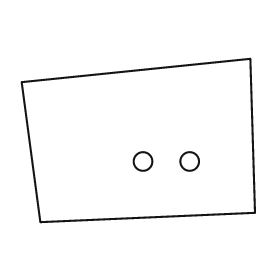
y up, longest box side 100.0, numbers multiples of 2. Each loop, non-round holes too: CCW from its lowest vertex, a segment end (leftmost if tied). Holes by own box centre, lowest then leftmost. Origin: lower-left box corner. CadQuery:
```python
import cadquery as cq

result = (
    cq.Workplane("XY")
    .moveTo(8.0, 0.0)
    .lineTo(100.0, 4.0)
    .lineTo(98.0, 70.0)
    .lineTo(0.0, 60.0)
    .close()
    .moveTo(52.0, 26.0)
    .circle(4.0)
    .moveTo(72.0, 26.0)
    .circle(4.0)
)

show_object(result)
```